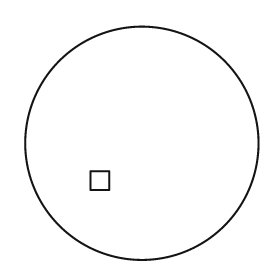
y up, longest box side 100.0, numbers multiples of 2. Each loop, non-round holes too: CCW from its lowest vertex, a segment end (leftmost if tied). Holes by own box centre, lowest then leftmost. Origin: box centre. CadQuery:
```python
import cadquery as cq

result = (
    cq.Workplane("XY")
    .moveTo(0.0, 0.0)
    .circle(50.0)
    .moveTo(-22.0, -20.0)
    .lineTo(-14.0, -20.0)
    .lineTo(-14.0, -12.0)
    .lineTo(-22.0, -12.0)
    .close()
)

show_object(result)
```